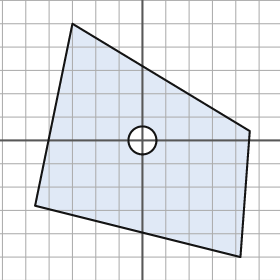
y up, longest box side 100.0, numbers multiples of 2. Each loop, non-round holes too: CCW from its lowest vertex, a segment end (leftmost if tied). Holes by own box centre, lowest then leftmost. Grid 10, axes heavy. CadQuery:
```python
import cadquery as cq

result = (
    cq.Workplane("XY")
    .moveTo(42.0, -50.0)
    .lineTo(46.0, 4.0)
    .lineTo(-30.0, 50.0)
    .lineTo(-46.0, -28.0)
    .close()
    .moveTo(0.0, 0.0)
    .circle(6.0)
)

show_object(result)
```